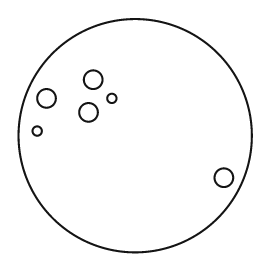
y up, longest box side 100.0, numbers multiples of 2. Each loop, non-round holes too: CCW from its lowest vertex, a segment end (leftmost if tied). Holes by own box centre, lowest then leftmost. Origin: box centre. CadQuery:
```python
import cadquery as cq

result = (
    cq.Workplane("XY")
    .moveTo(0.0, 0.0)
    .circle(50.0)
    .moveTo(38.0, -18.0)
    .circle(4.0)
    .moveTo(-42.0, 2.0)
    .circle(2.0)
    .moveTo(-20.0, 10.0)
    .circle(4.0)
    .moveTo(-38.0, 16.0)
    .circle(4.0)
    .moveTo(-10.0, 16.0)
    .circle(2.0)
    .moveTo(-18.0, 24.0)
    .circle(4.0)
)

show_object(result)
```